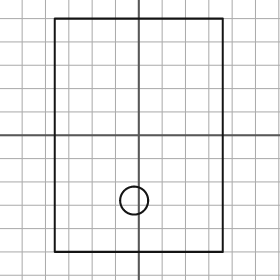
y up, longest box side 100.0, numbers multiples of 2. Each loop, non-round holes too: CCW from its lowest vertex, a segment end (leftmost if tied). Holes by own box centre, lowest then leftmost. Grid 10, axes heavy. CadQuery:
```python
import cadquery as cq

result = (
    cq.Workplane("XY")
    .moveTo(-36.0, -50.0)
    .lineTo(36.0, -50.0)
    .lineTo(36.0, 50.0)
    .lineTo(-36.0, 50.0)
    .close()
    .moveTo(-2.0, -28.0)
    .circle(6.0)
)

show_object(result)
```